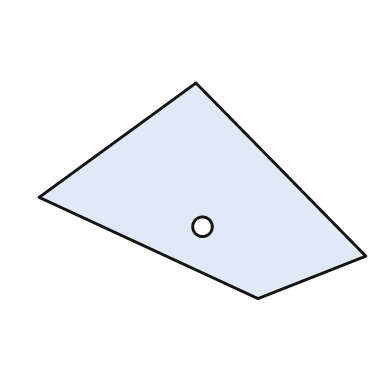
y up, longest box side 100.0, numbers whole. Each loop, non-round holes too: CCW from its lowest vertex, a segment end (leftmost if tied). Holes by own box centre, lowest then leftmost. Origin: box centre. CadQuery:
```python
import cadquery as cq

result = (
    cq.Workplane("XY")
    .moveTo(17.0, -33.0)
    .lineTo(50.0, -20.0)
    .lineTo(-2.0, 33.0)
    .lineTo(-50.0, -2.0)
    .close()
    .moveTo(0.0, -11.0)
    .circle(3.0)
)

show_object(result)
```